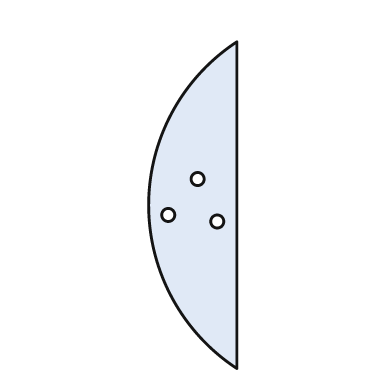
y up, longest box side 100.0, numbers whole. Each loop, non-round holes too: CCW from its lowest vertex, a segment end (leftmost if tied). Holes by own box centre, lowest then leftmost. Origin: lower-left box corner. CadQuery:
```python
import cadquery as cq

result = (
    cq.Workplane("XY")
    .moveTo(27.0, 0.0)
    .lineTo(27.0, 100.0)
    .threePointArc((0.0, 50.0), (27.0, 0.0))
    .close()
    .moveTo(21.0, 45.0)
    .circle(2.0)
    .moveTo(6.0, 47.0)
    .circle(2.0)
    .moveTo(15.0, 58.0)
    .circle(2.0)
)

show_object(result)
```